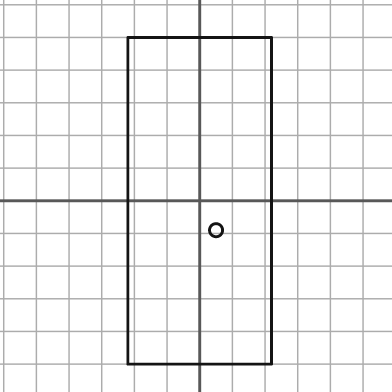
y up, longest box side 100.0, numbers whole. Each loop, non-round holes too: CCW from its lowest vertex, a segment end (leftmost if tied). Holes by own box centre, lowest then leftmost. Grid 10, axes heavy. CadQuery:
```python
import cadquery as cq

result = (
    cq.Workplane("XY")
    .moveTo(-22.0, -50.0)
    .lineTo(22.0, -50.0)
    .lineTo(22.0, 50.0)
    .lineTo(-22.0, 50.0)
    .close()
    .moveTo(5.0, -9.0)
    .circle(2.0)
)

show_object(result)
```